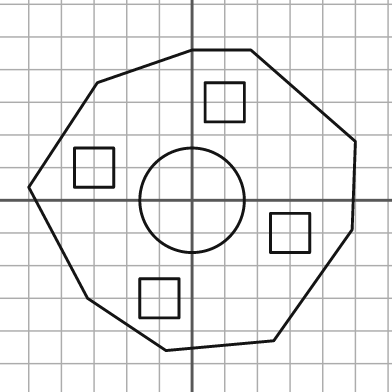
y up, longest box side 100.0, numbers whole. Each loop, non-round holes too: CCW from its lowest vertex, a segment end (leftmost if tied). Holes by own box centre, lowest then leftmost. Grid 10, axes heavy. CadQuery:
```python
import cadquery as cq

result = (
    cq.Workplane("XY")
    .moveTo(-8.0, -46.0)
    .lineTo(25.0, -43.0)
    .lineTo(49.0, -9.0)
    .lineTo(50.0, 18.0)
    .lineTo(18.0, 46.0)
    .lineTo(0.0, 46.0)
    .lineTo(-29.0, 36.0)
    .lineTo(-50.0, 4.0)
    .lineTo(-32.0, -30.0)
    .close()
    .moveTo(-16.0, -36.0)
    .lineTo(-4.0, -36.0)
    .lineTo(-4.0, -24.0)
    .lineTo(-16.0, -24.0)
    .close()
    .moveTo(24.0, -16.0)
    .lineTo(36.0, -16.0)
    .lineTo(36.0, -4.0)
    .lineTo(24.0, -4.0)
    .close()
    .moveTo(0.0, 0.0)
    .circle(16.0)
    .moveTo(-36.0, 4.0)
    .lineTo(-24.0, 4.0)
    .lineTo(-24.0, 16.0)
    .lineTo(-36.0, 16.0)
    .close()
    .moveTo(4.0, 24.0)
    .lineTo(16.0, 24.0)
    .lineTo(16.0, 36.0)
    .lineTo(4.0, 36.0)
    .close()
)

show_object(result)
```